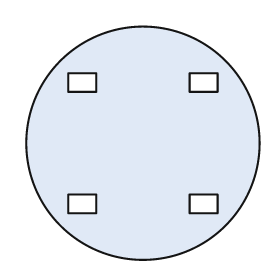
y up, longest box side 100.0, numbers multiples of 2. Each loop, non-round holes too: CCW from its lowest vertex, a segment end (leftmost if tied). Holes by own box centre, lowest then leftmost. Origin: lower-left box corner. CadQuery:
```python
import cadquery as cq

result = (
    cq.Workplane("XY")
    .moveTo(50.0, 50.0)
    .circle(50.0)
    .moveTo(18.0, 20.0)
    .lineTo(30.0, 20.0)
    .lineTo(30.0, 28.0)
    .lineTo(18.0, 28.0)
    .close()
    .moveTo(70.0, 20.0)
    .lineTo(82.0, 20.0)
    .lineTo(82.0, 28.0)
    .lineTo(70.0, 28.0)
    .close()
    .moveTo(18.0, 72.0)
    .lineTo(30.0, 72.0)
    .lineTo(30.0, 80.0)
    .lineTo(18.0, 80.0)
    .close()
    .moveTo(70.0, 72.0)
    .lineTo(82.0, 72.0)
    .lineTo(82.0, 80.0)
    .lineTo(70.0, 80.0)
    .close()
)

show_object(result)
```